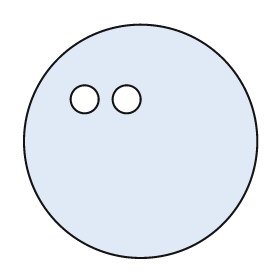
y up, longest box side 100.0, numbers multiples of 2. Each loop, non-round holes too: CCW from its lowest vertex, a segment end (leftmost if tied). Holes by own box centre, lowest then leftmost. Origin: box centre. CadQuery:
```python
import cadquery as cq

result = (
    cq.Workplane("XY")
    .moveTo(0.0, 0.0)
    .circle(50.0)
    .moveTo(-24.0, 18.0)
    .circle(6.0)
    .moveTo(-6.0, 18.0)
    .circle(6.0)
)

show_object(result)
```